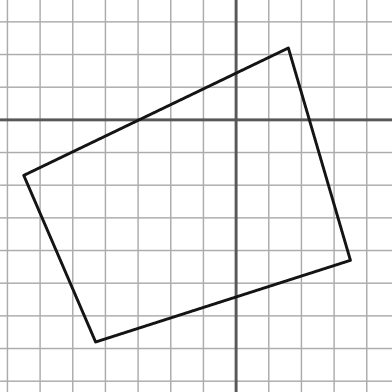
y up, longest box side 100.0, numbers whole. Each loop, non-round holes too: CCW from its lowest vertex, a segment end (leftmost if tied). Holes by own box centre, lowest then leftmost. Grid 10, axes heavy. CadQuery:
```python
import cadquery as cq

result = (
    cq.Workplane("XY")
    .moveTo(-43.0, -68.0)
    .lineTo(35.0, -43.0)
    .lineTo(16.0, 22.0)
    .lineTo(-65.0, -17.0)
    .close()
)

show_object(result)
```